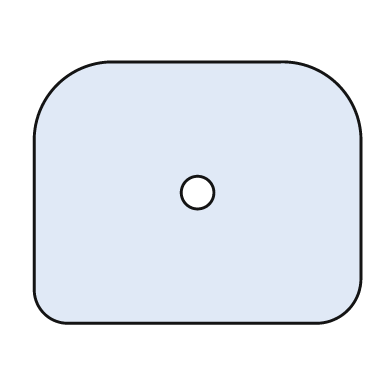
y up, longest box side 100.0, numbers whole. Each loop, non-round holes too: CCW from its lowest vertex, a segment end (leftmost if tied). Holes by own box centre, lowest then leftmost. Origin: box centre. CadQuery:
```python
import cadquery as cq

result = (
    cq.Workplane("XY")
    .moveTo(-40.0, -40.0)
    .lineTo(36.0, -40.0)
    .threePointArc((46.0, -36.0), (50.0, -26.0))
    .lineTo(50.0, 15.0)
    .threePointArc((43.0, 33.0), (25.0, 40.0))
    .lineTo(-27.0, 40.0)
    .threePointArc((-43.0, 33.0), (-50.0, 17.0))
    .lineTo(-50.0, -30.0)
    .threePointArc((-47.0, -37.0), (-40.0, -40.0))
    .close()
    .moveTo(0.0, 0.0)
    .circle(5.0)
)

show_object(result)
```